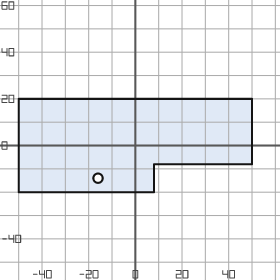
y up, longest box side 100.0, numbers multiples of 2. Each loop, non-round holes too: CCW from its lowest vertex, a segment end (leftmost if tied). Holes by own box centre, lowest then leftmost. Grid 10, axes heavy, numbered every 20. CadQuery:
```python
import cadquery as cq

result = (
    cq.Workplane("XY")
    .moveTo(-50.0, -20.0)
    .lineTo(8.0, -20.0)
    .lineTo(8.0, -8.0)
    .lineTo(50.0, -8.0)
    .lineTo(50.0, 20.0)
    .lineTo(-50.0, 20.0)
    .close()
    .moveTo(-16.0, -14.0)
    .circle(2.0)
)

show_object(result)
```